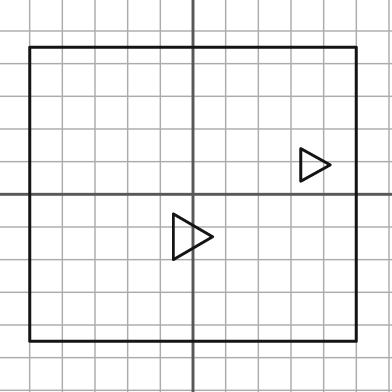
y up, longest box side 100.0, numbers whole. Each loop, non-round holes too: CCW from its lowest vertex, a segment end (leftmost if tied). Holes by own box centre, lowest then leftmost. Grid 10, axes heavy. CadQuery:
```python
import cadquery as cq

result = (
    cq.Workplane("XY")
    .moveTo(-50.0, -45.0)
    .lineTo(50.0, -45.0)
    .lineTo(50.0, 45.0)
    .lineTo(-50.0, 45.0)
    .close()
    .moveTo(-6.0, -20.0)
    .lineTo(6.0, -13.0)
    .lineTo(-6.0, -6.0)
    .close()
    .moveTo(33.0, 4.0)
    .lineTo(42.0, 9.0)
    .lineTo(33.0, 14.0)
    .close()
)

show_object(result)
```